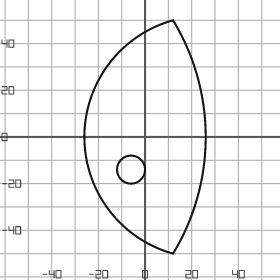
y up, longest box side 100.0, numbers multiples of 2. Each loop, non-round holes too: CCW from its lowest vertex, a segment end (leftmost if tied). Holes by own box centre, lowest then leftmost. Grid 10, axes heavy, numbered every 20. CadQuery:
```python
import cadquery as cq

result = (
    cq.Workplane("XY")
    .moveTo(12.0, -50.0)
    .threePointArc((26.0, 0.0), (12.0, 50.0))
    .threePointArc((-26.0, 0.0), (12.0, -50.0))
    .close()
    .moveTo(-6.0, -14.0)
    .circle(6.0)
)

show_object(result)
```